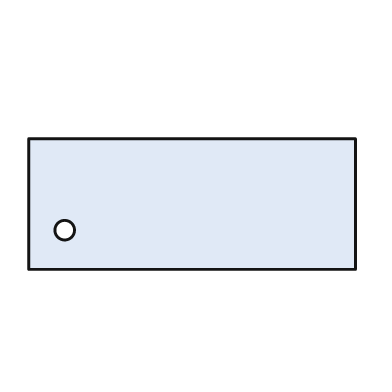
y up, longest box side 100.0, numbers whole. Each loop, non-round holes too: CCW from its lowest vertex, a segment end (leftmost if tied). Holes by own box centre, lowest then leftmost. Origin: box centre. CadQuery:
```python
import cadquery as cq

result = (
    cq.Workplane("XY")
    .moveTo(-50.0, -20.0)
    .lineTo(50.0, -20.0)
    .lineTo(50.0, 20.0)
    .lineTo(-50.0, 20.0)
    .close()
    .moveTo(-39.0, -8.0)
    .circle(3.0)
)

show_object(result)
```